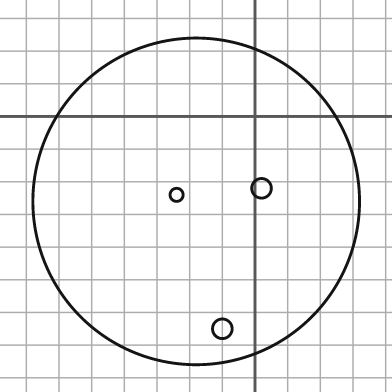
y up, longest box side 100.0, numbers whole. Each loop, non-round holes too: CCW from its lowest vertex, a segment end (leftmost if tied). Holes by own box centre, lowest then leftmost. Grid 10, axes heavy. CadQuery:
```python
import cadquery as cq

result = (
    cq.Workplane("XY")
    .moveTo(-18.0, -26.0)
    .circle(50.0)
    .moveTo(-10.0, -65.0)
    .circle(3.0)
    .moveTo(-24.0, -24.0)
    .circle(2.0)
    .moveTo(2.0, -22.0)
    .circle(3.0)
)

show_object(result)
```